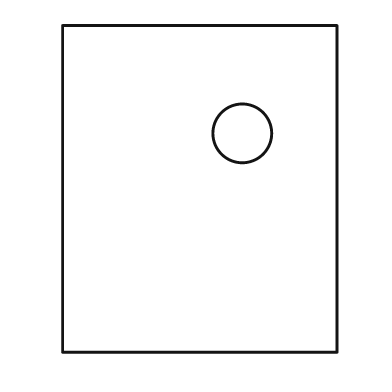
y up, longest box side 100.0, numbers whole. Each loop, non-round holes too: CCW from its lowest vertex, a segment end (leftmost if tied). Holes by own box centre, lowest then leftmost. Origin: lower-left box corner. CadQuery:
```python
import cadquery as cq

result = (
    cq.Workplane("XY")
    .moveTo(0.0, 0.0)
    .lineTo(84.0, 0.0)
    .lineTo(84.0, 100.0)
    .lineTo(0.0, 100.0)
    .close()
    .moveTo(55.0, 67.0)
    .circle(9.0)
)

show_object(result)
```